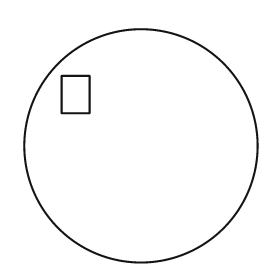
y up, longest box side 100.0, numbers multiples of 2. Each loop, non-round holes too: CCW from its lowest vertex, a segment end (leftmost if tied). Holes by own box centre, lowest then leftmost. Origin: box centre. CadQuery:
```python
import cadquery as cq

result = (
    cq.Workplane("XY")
    .moveTo(0.0, 0.0)
    .circle(50.0)
    .moveTo(-34.0, 14.0)
    .lineTo(-22.0, 14.0)
    .lineTo(-22.0, 30.0)
    .lineTo(-34.0, 30.0)
    .close()
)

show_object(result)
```